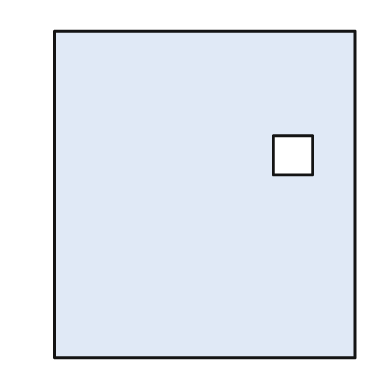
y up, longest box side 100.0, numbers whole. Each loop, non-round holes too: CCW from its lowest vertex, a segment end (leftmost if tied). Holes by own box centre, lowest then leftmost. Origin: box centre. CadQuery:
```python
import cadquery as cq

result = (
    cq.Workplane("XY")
    .moveTo(-46.0, -50.0)
    .lineTo(46.0, -50.0)
    .lineTo(46.0, 50.0)
    .lineTo(-46.0, 50.0)
    .close()
    .moveTo(21.0, 6.0)
    .lineTo(33.0, 6.0)
    .lineTo(33.0, 18.0)
    .lineTo(21.0, 18.0)
    .close()
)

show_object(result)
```